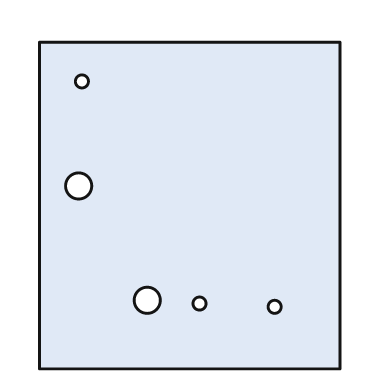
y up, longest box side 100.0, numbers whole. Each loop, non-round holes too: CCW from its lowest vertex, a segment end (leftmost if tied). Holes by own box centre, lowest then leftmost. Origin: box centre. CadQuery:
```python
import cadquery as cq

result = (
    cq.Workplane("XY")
    .moveTo(-46.0, -50.0)
    .lineTo(46.0, -50.0)
    .lineTo(46.0, 50.0)
    .lineTo(-46.0, 50.0)
    .close()
    .moveTo(26.0, -31.0)
    .circle(2.0)
    .moveTo(3.0, -30.0)
    .circle(2.0)
    .moveTo(-13.0, -29.0)
    .circle(4.0)
    .moveTo(-34.0, 6.0)
    .circle(4.0)
    .moveTo(-33.0, 38.0)
    .circle(2.0)
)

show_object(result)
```